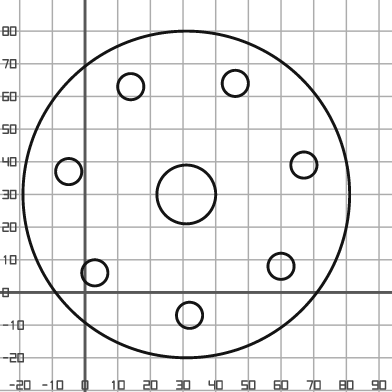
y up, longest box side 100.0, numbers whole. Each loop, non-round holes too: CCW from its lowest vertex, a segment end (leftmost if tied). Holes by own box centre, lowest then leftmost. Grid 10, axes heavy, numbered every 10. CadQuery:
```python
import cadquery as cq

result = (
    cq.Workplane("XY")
    .moveTo(31.0, 30.0)
    .circle(50.0)
    .moveTo(32.0, -7.0)
    .circle(4.0)
    .moveTo(3.0, 6.0)
    .circle(4.0)
    .moveTo(60.0, 8.0)
    .circle(4.0)
    .moveTo(31.0, 30.0)
    .circle(9.0)
    .moveTo(-5.0, 37.0)
    .circle(4.0)
    .moveTo(67.0, 39.0)
    .circle(4.0)
    .moveTo(14.0, 63.0)
    .circle(4.0)
    .moveTo(46.0, 64.0)
    .circle(4.0)
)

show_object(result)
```